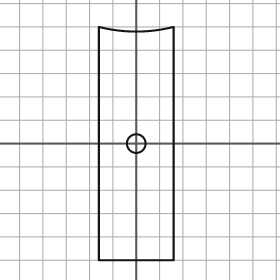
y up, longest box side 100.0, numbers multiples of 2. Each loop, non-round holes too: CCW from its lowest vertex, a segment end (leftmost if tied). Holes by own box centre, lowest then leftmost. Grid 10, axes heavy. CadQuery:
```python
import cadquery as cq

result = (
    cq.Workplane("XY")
    .moveTo(-16.0, -50.0)
    .lineTo(16.0, -50.0)
    .lineTo(16.0, 50.0)
    .threePointArc((0.0, 48.0), (-16.0, 50.0))
    .close()
    .moveTo(0.0, 0.0)
    .circle(4.0)
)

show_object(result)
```